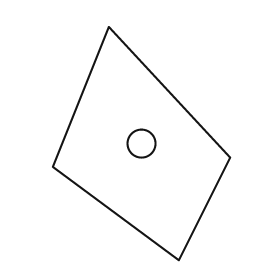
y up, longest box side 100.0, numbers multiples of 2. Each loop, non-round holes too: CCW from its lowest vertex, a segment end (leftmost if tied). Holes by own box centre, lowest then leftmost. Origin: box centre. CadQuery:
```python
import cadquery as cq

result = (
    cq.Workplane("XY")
    .moveTo(16.0, -50.0)
    .lineTo(38.0, -6.0)
    .lineTo(-14.0, 50.0)
    .lineTo(-38.0, -10.0)
    .close()
    .moveTo(0.0, 0.0)
    .circle(6.0)
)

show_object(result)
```